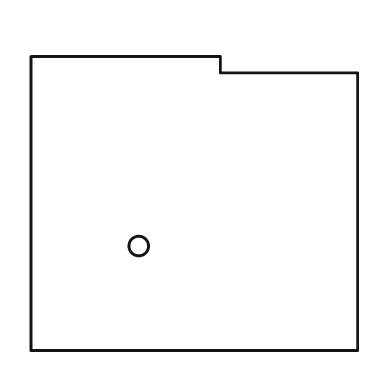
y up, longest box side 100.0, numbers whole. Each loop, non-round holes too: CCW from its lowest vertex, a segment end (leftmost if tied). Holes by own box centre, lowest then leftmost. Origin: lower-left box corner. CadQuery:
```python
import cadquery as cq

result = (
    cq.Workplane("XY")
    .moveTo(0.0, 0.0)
    .lineTo(100.0, 0.0)
    .lineTo(100.0, 85.0)
    .lineTo(58.0, 85.0)
    .lineTo(58.0, 90.0)
    .lineTo(0.0, 90.0)
    .close()
    .moveTo(33.0, 32.0)
    .circle(3.0)
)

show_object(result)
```